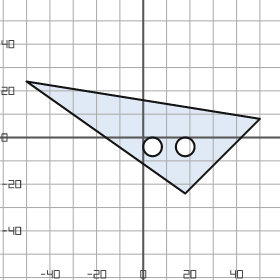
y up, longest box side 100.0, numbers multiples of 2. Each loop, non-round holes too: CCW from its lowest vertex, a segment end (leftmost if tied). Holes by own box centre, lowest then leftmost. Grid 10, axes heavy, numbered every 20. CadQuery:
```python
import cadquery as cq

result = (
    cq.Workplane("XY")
    .moveTo(18.0, -24.0)
    .lineTo(50.0, 8.0)
    .lineTo(-50.0, 24.0)
    .close()
    .moveTo(4.0, -4.0)
    .circle(4.0)
    .moveTo(18.0, -4.0)
    .circle(4.0)
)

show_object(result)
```